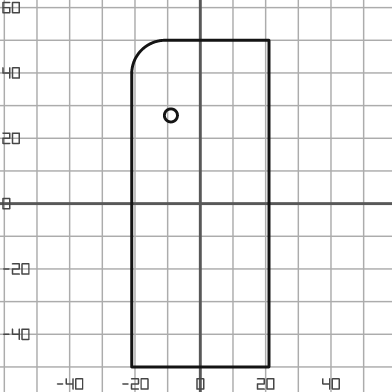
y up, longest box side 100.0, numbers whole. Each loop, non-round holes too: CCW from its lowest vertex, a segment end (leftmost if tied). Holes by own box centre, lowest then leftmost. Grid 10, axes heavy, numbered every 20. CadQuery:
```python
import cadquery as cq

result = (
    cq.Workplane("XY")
    .moveTo(-21.0, -50.0)
    .lineTo(21.0, -50.0)
    .lineTo(21.0, 50.0)
    .lineTo(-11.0, 50.0)
    .threePointArc((-18.0, 47.0), (-21.0, 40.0))
    .close()
    .moveTo(-9.0, 27.0)
    .circle(2.0)
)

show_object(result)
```